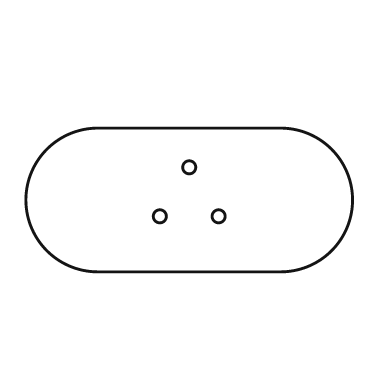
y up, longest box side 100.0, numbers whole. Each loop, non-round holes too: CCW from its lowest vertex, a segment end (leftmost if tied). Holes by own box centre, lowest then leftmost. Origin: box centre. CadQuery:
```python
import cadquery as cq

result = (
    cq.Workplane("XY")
    .moveTo(-28.0, -22.0)
    .lineTo(28.0, -22.0)
    .threePointArc((50.0, 0.0), (28.0, 22.0))
    .lineTo(-28.0, 22.0)
    .threePointArc((-50.0, 0.0), (-28.0, -22.0))
    .close()
    .moveTo(-9.0, -5.0)
    .circle(2.0)
    .moveTo(9.0, -5.0)
    .circle(2.0)
    .moveTo(0.0, 10.0)
    .circle(2.0)
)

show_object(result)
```